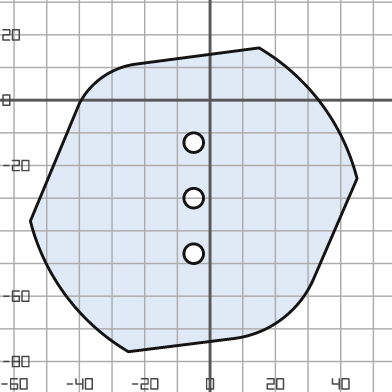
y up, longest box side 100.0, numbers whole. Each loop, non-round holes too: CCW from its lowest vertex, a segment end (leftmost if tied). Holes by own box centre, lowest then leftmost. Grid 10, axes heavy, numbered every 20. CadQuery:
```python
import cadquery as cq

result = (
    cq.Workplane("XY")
    .moveTo(-25.0, -77.0)
    .lineTo(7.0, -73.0)
    .threePointArc((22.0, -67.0), (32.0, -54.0))
    .lineTo(45.0, -24.0)
    .threePointArc((34.0, -1.0), (15.0, 16.0))
    .lineTo(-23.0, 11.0)
    .threePointArc((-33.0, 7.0), (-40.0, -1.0))
    .lineTo(-55.0, -37.0)
    .threePointArc((-44.0, -60.0), (-25.0, -77.0))
    .close()
    .moveTo(-5.0, -47.0)
    .circle(3.0)
    .moveTo(-5.0, -30.0)
    .circle(3.0)
    .moveTo(-5.0, -13.0)
    .circle(3.0)
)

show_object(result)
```